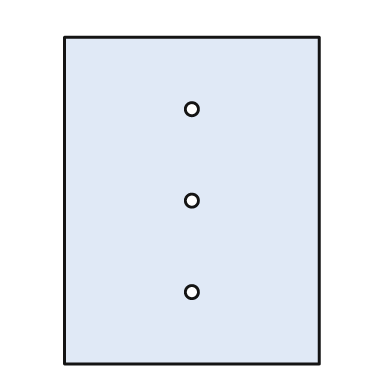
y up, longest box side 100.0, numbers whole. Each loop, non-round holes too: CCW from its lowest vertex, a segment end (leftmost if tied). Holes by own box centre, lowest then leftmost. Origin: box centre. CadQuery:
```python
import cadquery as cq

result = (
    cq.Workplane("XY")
    .moveTo(-39.0, -50.0)
    .lineTo(39.0, -50.0)
    .lineTo(39.0, 50.0)
    .lineTo(-39.0, 50.0)
    .close()
    .moveTo(0.0, -28.0)
    .circle(2.0)
    .moveTo(0.0, 0.0)
    .circle(2.0)
    .moveTo(0.0, 28.0)
    .circle(2.0)
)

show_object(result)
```